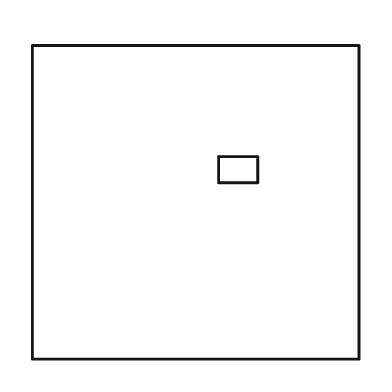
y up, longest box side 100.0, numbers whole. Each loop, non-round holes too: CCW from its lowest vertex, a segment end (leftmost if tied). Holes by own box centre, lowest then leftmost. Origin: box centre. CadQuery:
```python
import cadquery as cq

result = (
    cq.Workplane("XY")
    .moveTo(-50.0, -48.0)
    .lineTo(50.0, -48.0)
    .lineTo(50.0, 48.0)
    .lineTo(-50.0, 48.0)
    .close()
    .moveTo(7.0, 6.0)
    .lineTo(19.0, 6.0)
    .lineTo(19.0, 14.0)
    .lineTo(7.0, 14.0)
    .close()
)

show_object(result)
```